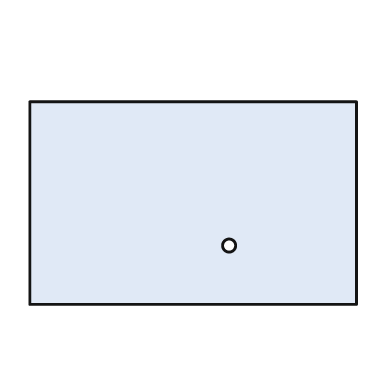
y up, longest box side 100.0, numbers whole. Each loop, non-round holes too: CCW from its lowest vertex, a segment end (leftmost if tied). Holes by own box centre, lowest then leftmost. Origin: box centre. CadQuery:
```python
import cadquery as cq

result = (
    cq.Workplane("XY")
    .moveTo(-50.0, -31.0)
    .lineTo(50.0, -31.0)
    .lineTo(50.0, 31.0)
    .lineTo(-50.0, 31.0)
    .close()
    .moveTo(11.0, -13.0)
    .circle(2.0)
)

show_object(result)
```